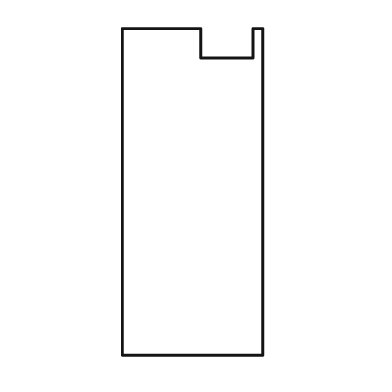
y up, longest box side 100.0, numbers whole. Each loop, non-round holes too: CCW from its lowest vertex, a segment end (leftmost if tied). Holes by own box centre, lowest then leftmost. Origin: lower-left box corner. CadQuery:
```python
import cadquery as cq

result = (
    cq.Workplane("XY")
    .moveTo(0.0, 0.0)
    .lineTo(43.0, 0.0)
    .lineTo(43.0, 100.0)
    .lineTo(40.0, 100.0)
    .lineTo(40.0, 91.0)
    .lineTo(24.0, 91.0)
    .lineTo(24.0, 100.0)
    .lineTo(0.0, 100.0)
    .close()
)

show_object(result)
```